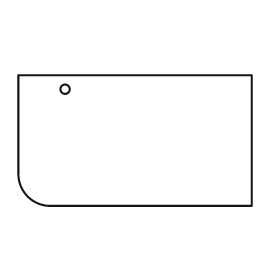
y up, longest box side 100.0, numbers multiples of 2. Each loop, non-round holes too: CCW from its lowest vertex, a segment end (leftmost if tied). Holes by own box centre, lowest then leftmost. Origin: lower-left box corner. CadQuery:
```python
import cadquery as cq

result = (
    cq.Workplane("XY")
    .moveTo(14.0, 0.0)
    .lineTo(100.0, 0.0)
    .lineTo(100.0, 56.0)
    .lineTo(0.0, 56.0)
    .lineTo(0.0, 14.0)
    .threePointArc((4.0, 4.0), (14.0, 0.0))
    .close()
    .moveTo(20.0, 50.0)
    .circle(2.0)
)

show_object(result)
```